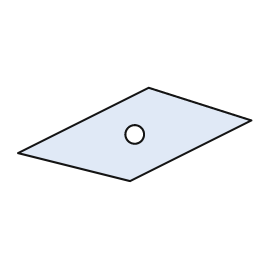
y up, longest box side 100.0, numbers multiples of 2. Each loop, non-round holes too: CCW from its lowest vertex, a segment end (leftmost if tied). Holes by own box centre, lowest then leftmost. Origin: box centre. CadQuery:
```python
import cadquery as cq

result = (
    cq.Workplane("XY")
    .moveTo(-2.0, -20.0)
    .lineTo(50.0, 6.0)
    .lineTo(6.0, 20.0)
    .lineTo(-50.0, -8.0)
    .close()
    .moveTo(0.0, 0.0)
    .circle(4.0)
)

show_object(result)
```